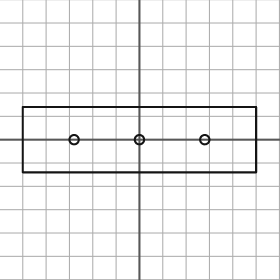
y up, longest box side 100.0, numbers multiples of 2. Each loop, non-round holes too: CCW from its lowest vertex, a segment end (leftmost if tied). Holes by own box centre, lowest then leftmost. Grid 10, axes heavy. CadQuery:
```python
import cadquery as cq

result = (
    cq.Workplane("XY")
    .moveTo(-50.0, -14.0)
    .lineTo(50.0, -14.0)
    .lineTo(50.0, 14.0)
    .lineTo(-50.0, 14.0)
    .close()
    .moveTo(-28.0, 0.0)
    .circle(2.0)
    .moveTo(0.0, 0.0)
    .circle(2.0)
    .moveTo(28.0, 0.0)
    .circle(2.0)
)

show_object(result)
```